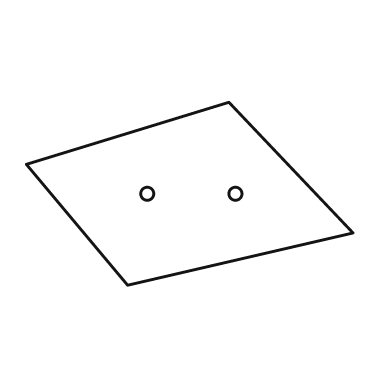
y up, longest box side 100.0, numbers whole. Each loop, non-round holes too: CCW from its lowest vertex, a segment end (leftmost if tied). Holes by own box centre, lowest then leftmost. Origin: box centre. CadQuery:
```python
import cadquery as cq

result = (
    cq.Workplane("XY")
    .moveTo(-19.0, -28.0)
    .lineTo(50.0, -12.0)
    .lineTo(12.0, 28.0)
    .lineTo(-50.0, 9.0)
    .close()
    .moveTo(-13.0, 0.0)
    .circle(2.0)
    .moveTo(14.0, 0.0)
    .circle(2.0)
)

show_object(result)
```